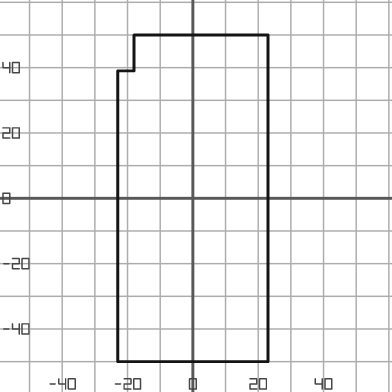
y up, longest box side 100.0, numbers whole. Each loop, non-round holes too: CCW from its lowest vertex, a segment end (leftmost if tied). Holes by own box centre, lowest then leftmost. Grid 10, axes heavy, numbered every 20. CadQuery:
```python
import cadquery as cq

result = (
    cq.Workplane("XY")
    .moveTo(-23.0, -50.0)
    .lineTo(23.0, -50.0)
    .lineTo(23.0, 50.0)
    .lineTo(-18.0, 50.0)
    .lineTo(-18.0, 39.0)
    .lineTo(-23.0, 39.0)
    .close()
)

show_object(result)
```